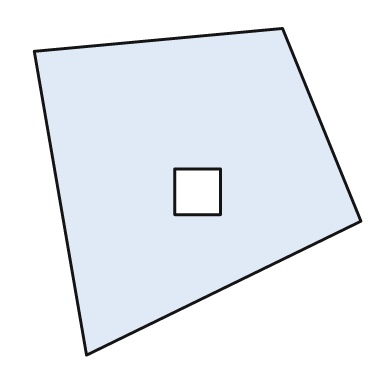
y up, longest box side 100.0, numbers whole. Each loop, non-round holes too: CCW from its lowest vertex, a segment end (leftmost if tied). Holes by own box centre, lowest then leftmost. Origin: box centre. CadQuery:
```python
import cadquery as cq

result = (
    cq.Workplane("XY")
    .moveTo(-34.0, -50.0)
    .lineTo(50.0, -9.0)
    .lineTo(26.0, 50.0)
    .lineTo(-50.0, 43.0)
    .close()
    .moveTo(-7.0, -7.0)
    .lineTo(7.0, -7.0)
    .lineTo(7.0, 7.0)
    .lineTo(-7.0, 7.0)
    .close()
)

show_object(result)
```